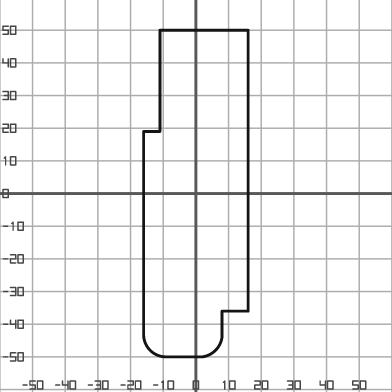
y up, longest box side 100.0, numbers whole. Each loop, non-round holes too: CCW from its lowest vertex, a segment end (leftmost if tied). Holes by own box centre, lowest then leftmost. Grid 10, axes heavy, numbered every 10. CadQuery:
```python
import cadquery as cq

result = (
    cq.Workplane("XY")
    .moveTo(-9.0, -50.0)
    .lineTo(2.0, -50.0)
    .threePointArc((6.0, -48.0), (8.0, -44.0))
    .lineTo(8.0, -36.0)
    .lineTo(16.0, -36.0)
    .lineTo(16.0, 50.0)
    .lineTo(-11.0, 50.0)
    .lineTo(-11.0, 19.0)
    .lineTo(-16.0, 19.0)
    .lineTo(-16.0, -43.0)
    .threePointArc((-14.0, -48.0), (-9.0, -50.0))
    .close()
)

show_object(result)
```